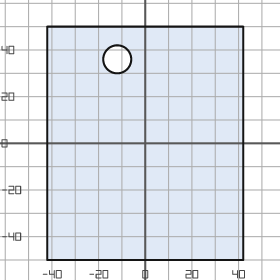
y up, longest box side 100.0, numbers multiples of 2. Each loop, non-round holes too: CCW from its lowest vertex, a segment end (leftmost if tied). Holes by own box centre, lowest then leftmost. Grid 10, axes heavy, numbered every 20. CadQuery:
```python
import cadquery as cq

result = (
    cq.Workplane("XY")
    .moveTo(-42.0, -50.0)
    .lineTo(42.0, -50.0)
    .lineTo(42.0, 50.0)
    .lineTo(-42.0, 50.0)
    .close()
    .moveTo(-12.0, 36.0)
    .circle(6.0)
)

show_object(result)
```